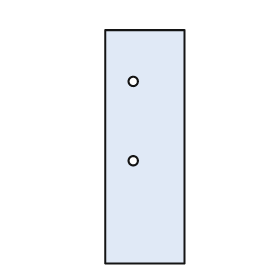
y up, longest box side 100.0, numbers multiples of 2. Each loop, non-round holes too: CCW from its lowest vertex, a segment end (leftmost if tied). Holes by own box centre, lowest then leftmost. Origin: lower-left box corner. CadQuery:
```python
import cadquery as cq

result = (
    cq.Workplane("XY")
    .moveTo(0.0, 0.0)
    .lineTo(34.0, 0.0)
    .lineTo(34.0, 100.0)
    .lineTo(0.0, 100.0)
    .close()
    .moveTo(12.0, 44.0)
    .circle(2.0)
    .moveTo(12.0, 78.0)
    .circle(2.0)
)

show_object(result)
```